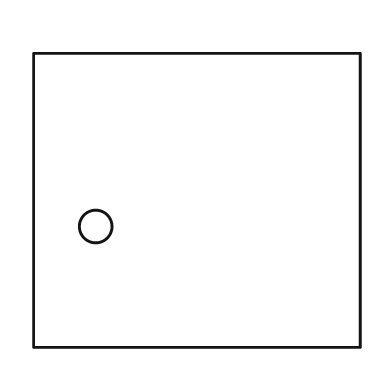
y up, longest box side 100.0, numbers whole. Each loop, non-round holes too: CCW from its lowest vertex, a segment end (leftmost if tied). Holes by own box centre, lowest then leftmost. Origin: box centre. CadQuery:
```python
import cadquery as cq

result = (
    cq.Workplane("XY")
    .moveTo(-50.0, -45.0)
    .lineTo(50.0, -45.0)
    .lineTo(50.0, 45.0)
    .lineTo(-50.0, 45.0)
    .close()
    .moveTo(-31.0, -8.0)
    .circle(5.0)
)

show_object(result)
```